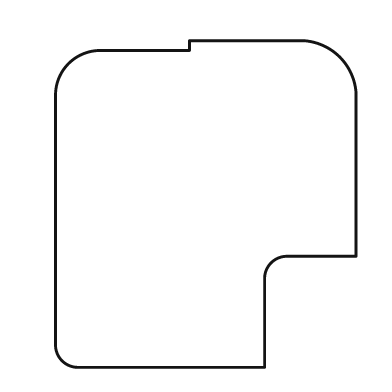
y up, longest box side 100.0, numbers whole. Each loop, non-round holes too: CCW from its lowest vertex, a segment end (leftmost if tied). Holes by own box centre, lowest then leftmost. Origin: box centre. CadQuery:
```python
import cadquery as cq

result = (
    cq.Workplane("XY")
    .moveTo(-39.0, -50.0)
    .lineTo(18.0, -50.0)
    .lineTo(18.0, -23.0)
    .threePointArc((20.0, -18.0), (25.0, -16.0))
    .lineTo(46.0, -16.0)
    .lineTo(46.0, 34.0)
    .threePointArc((41.0, 45.0), (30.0, 50.0))
    .lineTo(-5.0, 50.0)
    .lineTo(-5.0, 47.0)
    .lineTo(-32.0, 47.0)
    .threePointArc((-42.0, 43.0), (-46.0, 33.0))
    .lineTo(-46.0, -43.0)
    .threePointArc((-44.0, -48.0), (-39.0, -50.0))
    .close()
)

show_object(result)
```